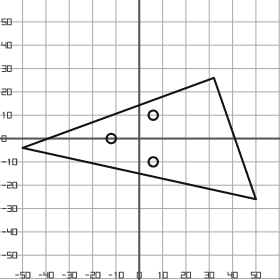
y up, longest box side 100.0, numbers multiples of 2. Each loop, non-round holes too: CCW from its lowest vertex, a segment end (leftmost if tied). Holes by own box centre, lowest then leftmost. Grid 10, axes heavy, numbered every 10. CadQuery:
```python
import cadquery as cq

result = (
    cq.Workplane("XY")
    .moveTo(50.0, -26.0)
    .lineTo(32.0, 26.0)
    .lineTo(-50.0, -4.0)
    .close()
    .moveTo(6.0, -10.0)
    .circle(2.0)
    .moveTo(-12.0, 0.0)
    .circle(2.0)
    .moveTo(6.0, 10.0)
    .circle(2.0)
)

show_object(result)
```